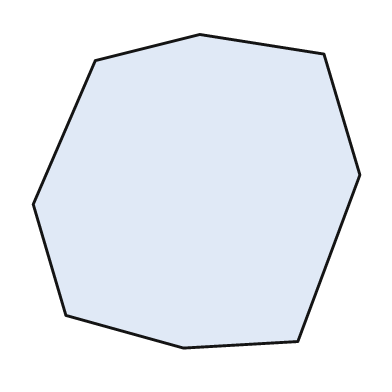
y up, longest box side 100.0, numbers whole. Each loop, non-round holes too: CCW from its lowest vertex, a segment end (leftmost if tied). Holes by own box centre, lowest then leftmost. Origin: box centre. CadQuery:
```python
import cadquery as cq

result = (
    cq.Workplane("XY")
    .moveTo(-4.0, -48.0)
    .lineTo(31.0, -46.0)
    .lineTo(50.0, 5.0)
    .lineTo(39.0, 42.0)
    .lineTo(1.0, 48.0)
    .lineTo(-31.0, 40.0)
    .lineTo(-50.0, -4.0)
    .lineTo(-40.0, -38.0)
    .close()
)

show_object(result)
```